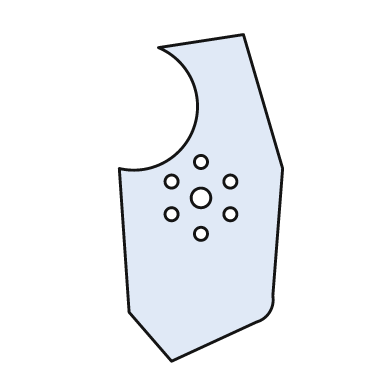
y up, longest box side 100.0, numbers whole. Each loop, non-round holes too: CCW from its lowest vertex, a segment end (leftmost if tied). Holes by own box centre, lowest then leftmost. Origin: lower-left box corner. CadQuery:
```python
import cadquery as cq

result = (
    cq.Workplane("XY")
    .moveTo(16.0, 0.0)
    .lineTo(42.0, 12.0)
    .threePointArc((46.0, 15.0), (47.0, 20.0))
    .lineTo(50.0, 59.0)
    .lineTo(38.0, 100.0)
    .lineTo(12.0, 96.0)
    .threePointArc((23.0, 72.0), (0.0, 59.0))
    .lineTo(3.0, 15.0)
    .close()
    .moveTo(25.0, 39.0)
    .circle(2.0)
    .moveTo(16.0, 45.0)
    .circle(2.0)
    .moveTo(34.0, 45.0)
    .circle(2.0)
    .moveTo(25.0, 50.0)
    .circle(3.0)
    .moveTo(16.0, 55.0)
    .circle(2.0)
    .moveTo(34.0, 55.0)
    .circle(2.0)
    .moveTo(25.0, 61.0)
    .circle(2.0)
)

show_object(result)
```